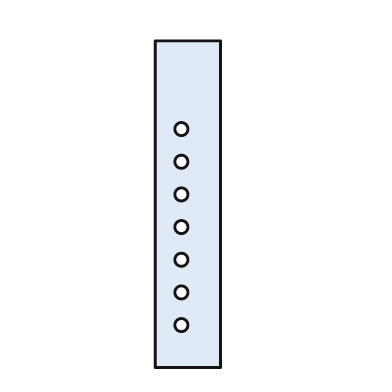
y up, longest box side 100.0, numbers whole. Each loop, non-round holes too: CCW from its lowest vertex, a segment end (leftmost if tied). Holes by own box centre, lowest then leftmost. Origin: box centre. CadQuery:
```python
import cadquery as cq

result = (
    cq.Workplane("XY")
    .moveTo(-10.0, -50.0)
    .lineTo(10.0, -50.0)
    .lineTo(10.0, 50.0)
    .lineTo(-10.0, 50.0)
    .close()
    .moveTo(-2.0, -37.0)
    .circle(2.0)
    .moveTo(-2.0, -27.0)
    .circle(2.0)
    .moveTo(-2.0, -17.0)
    .circle(2.0)
    .moveTo(-2.0, -7.0)
    .circle(2.0)
    .moveTo(-2.0, 3.0)
    .circle(2.0)
    .moveTo(-2.0, 13.0)
    .circle(2.0)
    .moveTo(-2.0, 23.0)
    .circle(2.0)
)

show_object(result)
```